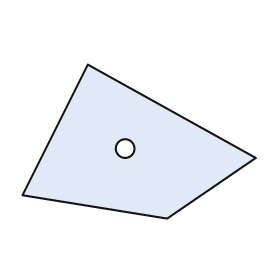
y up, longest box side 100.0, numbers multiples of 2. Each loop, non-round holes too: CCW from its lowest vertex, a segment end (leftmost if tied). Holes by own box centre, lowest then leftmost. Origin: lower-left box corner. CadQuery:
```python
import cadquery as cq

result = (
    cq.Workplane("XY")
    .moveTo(62.0, 0.0)
    .lineTo(100.0, 26.0)
    .lineTo(28.0, 66.0)
    .lineTo(0.0, 10.0)
    .close()
    .moveTo(44.0, 30.0)
    .circle(4.0)
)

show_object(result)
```